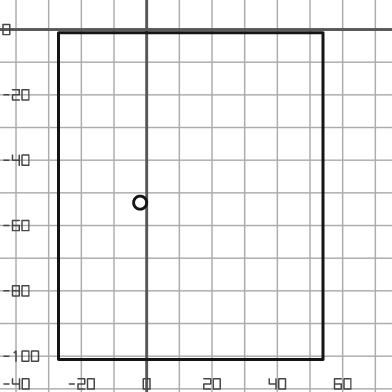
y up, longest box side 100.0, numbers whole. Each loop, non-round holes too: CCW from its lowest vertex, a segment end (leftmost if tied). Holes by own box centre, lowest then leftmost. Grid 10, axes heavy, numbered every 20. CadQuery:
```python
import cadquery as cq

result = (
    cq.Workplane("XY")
    .moveTo(-27.0, -101.0)
    .lineTo(54.0, -101.0)
    .lineTo(54.0, -1.0)
    .lineTo(-27.0, -1.0)
    .close()
    .moveTo(-2.0, -53.0)
    .circle(2.0)
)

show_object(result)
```